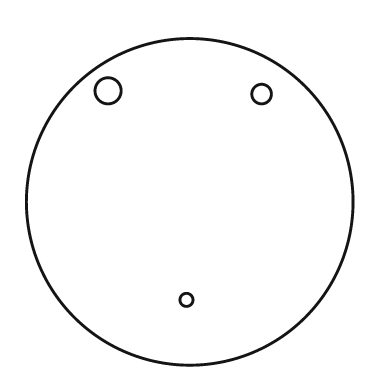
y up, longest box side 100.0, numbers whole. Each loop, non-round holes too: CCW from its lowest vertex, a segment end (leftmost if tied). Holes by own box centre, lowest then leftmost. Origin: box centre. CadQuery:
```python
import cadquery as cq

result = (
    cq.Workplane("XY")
    .moveTo(0.0, 0.0)
    .circle(50.0)
    .moveTo(-1.0, -30.0)
    .circle(2.0)
    .moveTo(22.0, 33.0)
    .circle(3.0)
    .moveTo(-25.0, 34.0)
    .circle(4.0)
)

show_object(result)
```